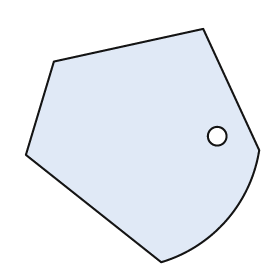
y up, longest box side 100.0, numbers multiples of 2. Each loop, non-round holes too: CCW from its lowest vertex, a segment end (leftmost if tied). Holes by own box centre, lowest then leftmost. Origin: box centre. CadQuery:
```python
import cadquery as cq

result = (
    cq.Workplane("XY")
    .moveTo(8.0, -50.0)
    .threePointArc((36.0, -32.0), (50.0, -2.0))
    .lineTo(26.0, 50.0)
    .lineTo(-38.0, 36.0)
    .lineTo(-50.0, -4.0)
    .close()
    .moveTo(32.0, 4.0)
    .circle(4.0)
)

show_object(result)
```